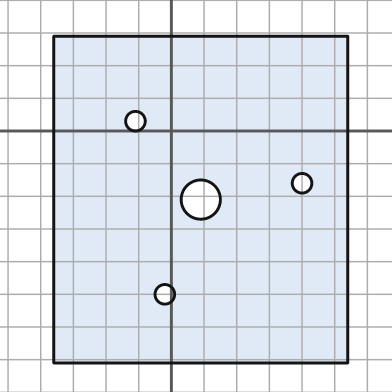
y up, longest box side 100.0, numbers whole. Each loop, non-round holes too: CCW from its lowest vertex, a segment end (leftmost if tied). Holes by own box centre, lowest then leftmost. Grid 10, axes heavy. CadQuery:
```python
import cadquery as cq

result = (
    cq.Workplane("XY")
    .moveTo(-36.0, -71.0)
    .lineTo(54.0, -71.0)
    .lineTo(54.0, 29.0)
    .lineTo(-36.0, 29.0)
    .close()
    .moveTo(-2.0, -50.0)
    .circle(3.0)
    .moveTo(9.0, -21.0)
    .circle(6.0)
    .moveTo(40.0, -16.0)
    .circle(3.0)
    .moveTo(-11.0, 3.0)
    .circle(3.0)
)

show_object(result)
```